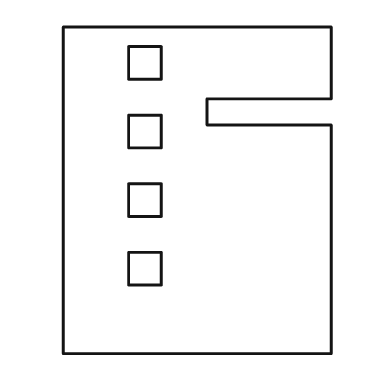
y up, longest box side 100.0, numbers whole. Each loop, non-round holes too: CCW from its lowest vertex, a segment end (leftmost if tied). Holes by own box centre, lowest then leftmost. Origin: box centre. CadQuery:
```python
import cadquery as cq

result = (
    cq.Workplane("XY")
    .moveTo(-41.0, -50.0)
    .lineTo(41.0, -50.0)
    .lineTo(41.0, 20.0)
    .lineTo(3.0, 20.0)
    .lineTo(3.0, 28.0)
    .lineTo(41.0, 28.0)
    .lineTo(41.0, 50.0)
    .lineTo(-41.0, 50.0)
    .close()
    .moveTo(-21.0, -29.0)
    .lineTo(-11.0, -29.0)
    .lineTo(-11.0, -19.0)
    .lineTo(-21.0, -19.0)
    .close()
    .moveTo(-21.0, -8.0)
    .lineTo(-11.0, -8.0)
    .lineTo(-11.0, 2.0)
    .lineTo(-21.0, 2.0)
    .close()
    .moveTo(-21.0, 13.0)
    .lineTo(-11.0, 13.0)
    .lineTo(-11.0, 23.0)
    .lineTo(-21.0, 23.0)
    .close()
    .moveTo(-21.0, 34.0)
    .lineTo(-11.0, 34.0)
    .lineTo(-11.0, 44.0)
    .lineTo(-21.0, 44.0)
    .close()
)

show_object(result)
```